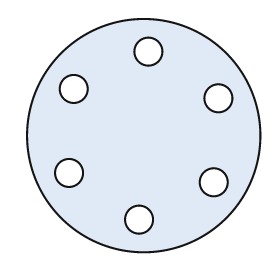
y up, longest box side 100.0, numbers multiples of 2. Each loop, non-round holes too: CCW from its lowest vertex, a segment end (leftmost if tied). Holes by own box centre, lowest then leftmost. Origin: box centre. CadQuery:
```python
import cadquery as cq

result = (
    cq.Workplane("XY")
    .moveTo(0.0, 0.0)
    .circle(50.0)
    .moveTo(-2.0, -36.0)
    .circle(6.0)
    .moveTo(30.0, -20.0)
    .circle(6.0)
    .moveTo(-32.0, -16.0)
    .circle(6.0)
    .moveTo(32.0, 16.0)
    .circle(6.0)
    .moveTo(-30.0, 20.0)
    .circle(6.0)
    .moveTo(2.0, 36.0)
    .circle(6.0)
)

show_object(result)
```